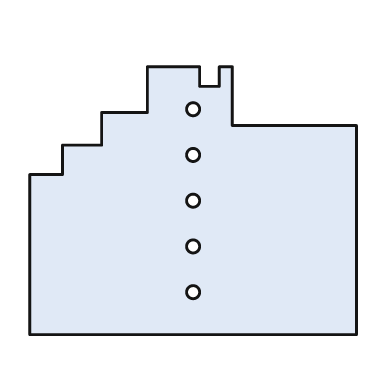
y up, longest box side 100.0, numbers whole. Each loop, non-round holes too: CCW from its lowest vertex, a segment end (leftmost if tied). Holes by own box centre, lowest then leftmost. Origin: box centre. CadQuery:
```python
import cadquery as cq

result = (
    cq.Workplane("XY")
    .moveTo(-50.0, -41.0)
    .lineTo(50.0, -41.0)
    .lineTo(50.0, 23.0)
    .lineTo(12.0, 23.0)
    .lineTo(12.0, 41.0)
    .lineTo(8.0, 41.0)
    .lineTo(8.0, 35.0)
    .lineTo(2.0, 35.0)
    .lineTo(2.0, 41.0)
    .lineTo(-14.0, 41.0)
    .lineTo(-14.0, 27.0)
    .lineTo(-28.0, 27.0)
    .lineTo(-28.0, 17.0)
    .lineTo(-40.0, 17.0)
    .lineTo(-40.0, 8.0)
    .lineTo(-50.0, 8.0)
    .close()
    .moveTo(0.0, -28.0)
    .circle(2.0)
    .moveTo(0.0, -14.0)
    .circle(2.0)
    .moveTo(0.0, 0.0)
    .circle(2.0)
    .moveTo(0.0, 14.0)
    .circle(2.0)
    .moveTo(0.0, 28.0)
    .circle(2.0)
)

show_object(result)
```